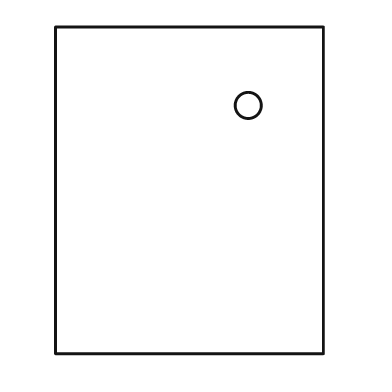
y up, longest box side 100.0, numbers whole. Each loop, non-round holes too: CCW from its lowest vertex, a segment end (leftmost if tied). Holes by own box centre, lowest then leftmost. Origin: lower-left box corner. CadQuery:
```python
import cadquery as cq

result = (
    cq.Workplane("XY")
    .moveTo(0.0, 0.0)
    .lineTo(82.0, 0.0)
    .lineTo(82.0, 100.0)
    .lineTo(0.0, 100.0)
    .close()
    .moveTo(59.0, 76.0)
    .circle(4.0)
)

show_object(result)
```